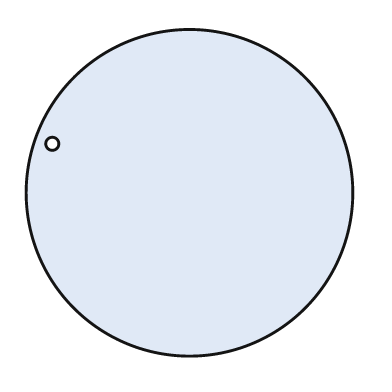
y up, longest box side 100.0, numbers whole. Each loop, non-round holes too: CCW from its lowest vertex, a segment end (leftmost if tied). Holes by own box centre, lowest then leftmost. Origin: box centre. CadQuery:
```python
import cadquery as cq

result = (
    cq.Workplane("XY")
    .moveTo(0.0, 0.0)
    .circle(50.0)
    .moveTo(-42.0, 15.0)
    .circle(2.0)
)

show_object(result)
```